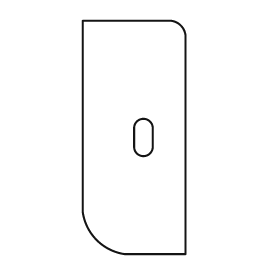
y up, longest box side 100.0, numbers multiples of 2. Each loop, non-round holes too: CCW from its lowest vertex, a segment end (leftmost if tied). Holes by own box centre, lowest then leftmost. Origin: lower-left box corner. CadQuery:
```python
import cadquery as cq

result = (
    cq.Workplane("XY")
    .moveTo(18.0, 0.0)
    .lineTo(44.0, 0.0)
    .lineTo(44.0, 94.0)
    .threePointArc((42.0, 98.0), (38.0, 100.0))
    .lineTo(0.0, 100.0)
    .lineTo(0.0, 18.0)
    .threePointArc((6.0, 6.0), (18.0, 0.0))
    .close()
    .moveTo(22.0, 46.0)
    .threePointArc((26.0, 42.0), (30.0, 46.0))
    .lineTo(30.0, 54.0)
    .threePointArc((26.0, 58.0), (22.0, 54.0))
    .close()
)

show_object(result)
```